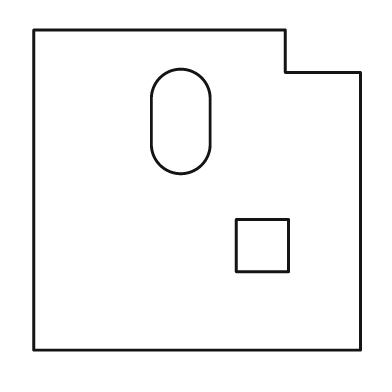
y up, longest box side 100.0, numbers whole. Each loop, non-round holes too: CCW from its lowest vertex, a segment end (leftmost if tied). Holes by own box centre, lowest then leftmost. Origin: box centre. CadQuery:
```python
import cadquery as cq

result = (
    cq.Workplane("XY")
    .moveTo(-50.0, -49.0)
    .lineTo(50.0, -49.0)
    .lineTo(50.0, 36.0)
    .lineTo(27.0, 36.0)
    .lineTo(27.0, 49.0)
    .lineTo(-50.0, 49.0)
    .close()
    .moveTo(12.0, -25.0)
    .lineTo(28.0, -25.0)
    .lineTo(28.0, -9.0)
    .lineTo(12.0, -9.0)
    .close()
    .moveTo(-14.0, 14.0)
    .threePointArc((-5.0, 5.0), (4.0, 14.0))
    .lineTo(4.0, 28.0)
    .threePointArc((-5.0, 37.0), (-14.0, 28.0))
    .close()
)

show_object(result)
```